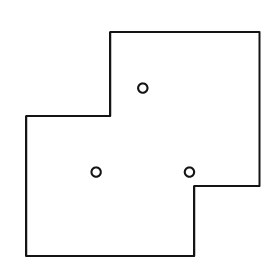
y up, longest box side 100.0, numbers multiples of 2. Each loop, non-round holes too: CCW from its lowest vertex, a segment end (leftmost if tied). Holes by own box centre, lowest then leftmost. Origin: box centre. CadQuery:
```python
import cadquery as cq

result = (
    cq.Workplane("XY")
    .moveTo(-50.0, -48.0)
    .lineTo(22.0, -48.0)
    .lineTo(22.0, -18.0)
    .lineTo(50.0, -18.0)
    .lineTo(50.0, 48.0)
    .lineTo(-14.0, 48.0)
    .lineTo(-14.0, 12.0)
    .lineTo(-50.0, 12.0)
    .close()
    .moveTo(-20.0, -12.0)
    .circle(2.0)
    .moveTo(20.0, -12.0)
    .circle(2.0)
    .moveTo(0.0, 24.0)
    .circle(2.0)
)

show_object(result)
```